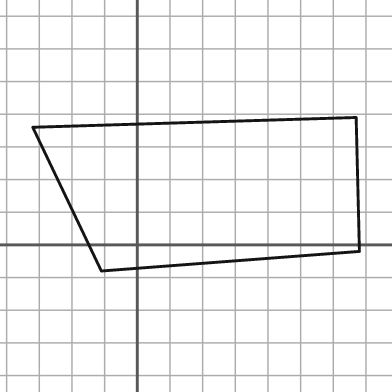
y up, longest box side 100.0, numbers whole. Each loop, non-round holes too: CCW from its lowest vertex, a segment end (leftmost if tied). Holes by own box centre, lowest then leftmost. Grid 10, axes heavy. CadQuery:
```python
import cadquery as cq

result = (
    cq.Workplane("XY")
    .moveTo(-11.0, -8.0)
    .lineTo(68.0, -2.0)
    .lineTo(67.0, 39.0)
    .lineTo(-32.0, 36.0)
    .close()
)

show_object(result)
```